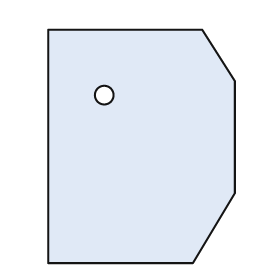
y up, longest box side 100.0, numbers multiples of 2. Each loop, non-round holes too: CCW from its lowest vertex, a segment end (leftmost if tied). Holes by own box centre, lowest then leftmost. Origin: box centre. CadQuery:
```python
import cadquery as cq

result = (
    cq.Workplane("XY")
    .moveTo(-40.0, -50.0)
    .lineTo(22.0, -50.0)
    .lineTo(40.0, -20.0)
    .lineTo(40.0, 28.0)
    .lineTo(26.0, 50.0)
    .lineTo(-40.0, 50.0)
    .close()
    .moveTo(-16.0, 22.0)
    .circle(4.0)
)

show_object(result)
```